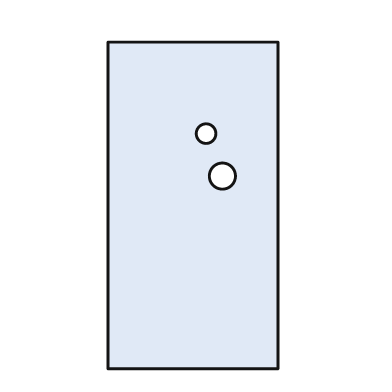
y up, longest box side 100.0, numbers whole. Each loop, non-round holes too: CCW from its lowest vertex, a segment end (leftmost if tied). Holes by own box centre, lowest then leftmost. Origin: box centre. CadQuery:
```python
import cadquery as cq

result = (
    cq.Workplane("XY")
    .moveTo(-26.0, -50.0)
    .lineTo(26.0, -50.0)
    .lineTo(26.0, 50.0)
    .lineTo(-26.0, 50.0)
    .close()
    .moveTo(9.0, 9.0)
    .circle(4.0)
    .moveTo(4.0, 22.0)
    .circle(3.0)
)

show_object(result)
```